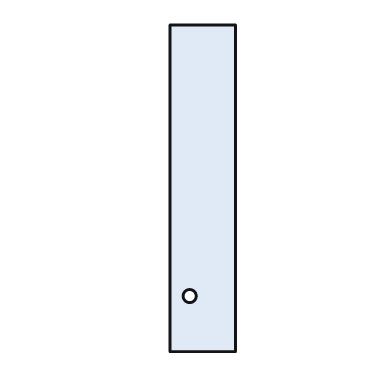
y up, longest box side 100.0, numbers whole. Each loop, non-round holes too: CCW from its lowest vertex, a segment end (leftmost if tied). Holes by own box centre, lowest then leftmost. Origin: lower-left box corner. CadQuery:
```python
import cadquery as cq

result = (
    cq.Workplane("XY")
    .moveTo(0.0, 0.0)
    .lineTo(20.0, 0.0)
    .lineTo(20.0, 100.0)
    .lineTo(0.0, 100.0)
    .close()
    .moveTo(6.0, 17.0)
    .circle(2.0)
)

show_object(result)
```